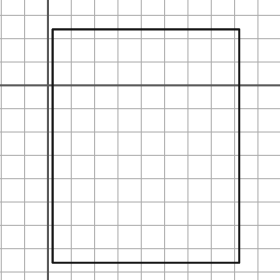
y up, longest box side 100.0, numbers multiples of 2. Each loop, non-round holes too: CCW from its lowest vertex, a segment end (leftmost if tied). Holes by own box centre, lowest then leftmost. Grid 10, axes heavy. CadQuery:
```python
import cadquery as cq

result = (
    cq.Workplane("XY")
    .moveTo(2.0, -76.0)
    .lineTo(82.0, -76.0)
    .lineTo(82.0, 24.0)
    .lineTo(2.0, 24.0)
    .close()
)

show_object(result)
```